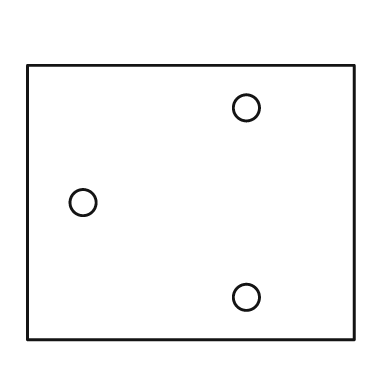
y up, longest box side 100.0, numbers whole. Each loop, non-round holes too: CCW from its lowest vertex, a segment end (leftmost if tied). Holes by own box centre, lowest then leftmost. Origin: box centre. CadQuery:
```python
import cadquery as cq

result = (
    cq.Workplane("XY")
    .moveTo(-50.0, -42.0)
    .lineTo(50.0, -42.0)
    .lineTo(50.0, 42.0)
    .lineTo(-50.0, 42.0)
    .close()
    .moveTo(17.0, -29.0)
    .circle(4.0)
    .moveTo(-33.0, 0.0)
    .circle(4.0)
    .moveTo(17.0, 29.0)
    .circle(4.0)
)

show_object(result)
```